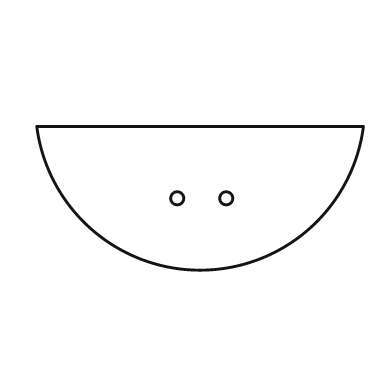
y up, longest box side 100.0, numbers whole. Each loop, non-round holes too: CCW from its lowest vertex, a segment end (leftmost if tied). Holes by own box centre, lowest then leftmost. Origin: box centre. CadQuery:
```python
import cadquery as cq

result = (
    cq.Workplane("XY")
    .moveTo(-50.0, 22.0)
    .threePointArc((0.0, -22.0), (50.0, 22.0))
    .close()
    .moveTo(-7.0, 0.0)
    .circle(2.0)
    .moveTo(8.0, 0.0)
    .circle(2.0)
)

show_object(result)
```